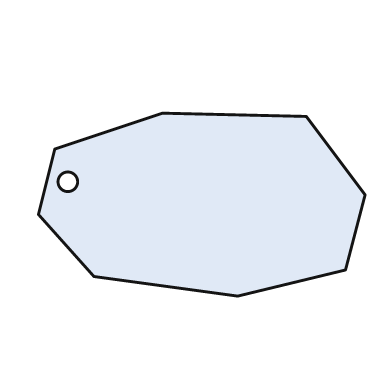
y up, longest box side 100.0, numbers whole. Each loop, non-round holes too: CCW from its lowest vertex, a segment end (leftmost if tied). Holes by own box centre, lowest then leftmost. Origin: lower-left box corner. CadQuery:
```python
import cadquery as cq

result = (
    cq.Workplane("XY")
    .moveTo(61.0, 0.0)
    .lineTo(94.0, 8.0)
    .lineTo(100.0, 31.0)
    .lineTo(82.0, 55.0)
    .lineTo(38.0, 56.0)
    .lineTo(5.0, 45.0)
    .lineTo(0.0, 25.0)
    .lineTo(17.0, 6.0)
    .close()
    .moveTo(9.0, 35.0)
    .circle(3.0)
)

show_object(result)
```